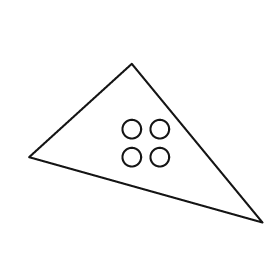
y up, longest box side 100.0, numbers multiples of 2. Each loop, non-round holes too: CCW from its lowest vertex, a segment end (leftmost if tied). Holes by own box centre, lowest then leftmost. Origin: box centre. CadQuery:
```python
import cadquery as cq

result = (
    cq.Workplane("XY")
    .moveTo(50.0, -34.0)
    .lineTo(-6.0, 34.0)
    .lineTo(-50.0, -6.0)
    .close()
    .moveTo(-6.0, -6.0)
    .circle(4.0)
    .moveTo(6.0, -6.0)
    .circle(4.0)
    .moveTo(-6.0, 6.0)
    .circle(4.0)
    .moveTo(6.0, 6.0)
    .circle(4.0)
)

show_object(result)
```